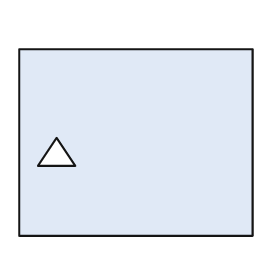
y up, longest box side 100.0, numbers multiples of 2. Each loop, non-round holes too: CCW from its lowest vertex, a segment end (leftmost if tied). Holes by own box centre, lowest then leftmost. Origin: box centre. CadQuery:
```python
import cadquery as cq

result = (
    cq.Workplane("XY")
    .moveTo(-50.0, -40.0)
    .lineTo(50.0, -40.0)
    .lineTo(50.0, 40.0)
    .lineTo(-50.0, 40.0)
    .close()
    .moveTo(-42.0, -10.0)
    .lineTo(-26.0, -10.0)
    .lineTo(-34.0, 2.0)
    .close()
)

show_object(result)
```